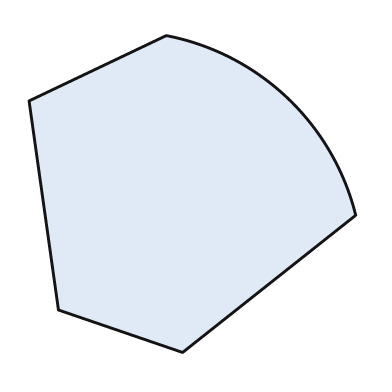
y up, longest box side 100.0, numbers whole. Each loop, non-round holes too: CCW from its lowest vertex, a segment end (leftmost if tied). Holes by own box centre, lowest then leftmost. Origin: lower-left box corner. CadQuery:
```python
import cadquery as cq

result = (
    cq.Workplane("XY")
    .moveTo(47.0, 0.0)
    .lineTo(100.0, 42.0)
    .threePointArc((79.0, 78.0), (42.0, 97.0))
    .lineTo(0.0, 77.0)
    .lineTo(9.0, 13.0)
    .close()
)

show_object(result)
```